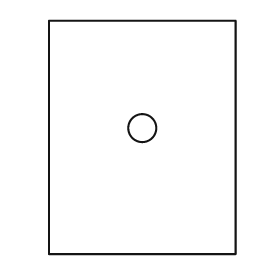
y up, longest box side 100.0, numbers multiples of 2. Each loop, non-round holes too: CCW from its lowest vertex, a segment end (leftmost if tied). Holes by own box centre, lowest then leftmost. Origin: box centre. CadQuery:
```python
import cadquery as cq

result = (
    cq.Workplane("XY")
    .moveTo(-40.0, -50.0)
    .lineTo(40.0, -50.0)
    .lineTo(40.0, 50.0)
    .lineTo(-40.0, 50.0)
    .close()
    .moveTo(0.0, 4.0)
    .circle(6.0)
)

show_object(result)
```